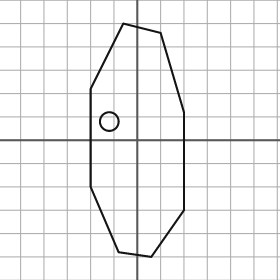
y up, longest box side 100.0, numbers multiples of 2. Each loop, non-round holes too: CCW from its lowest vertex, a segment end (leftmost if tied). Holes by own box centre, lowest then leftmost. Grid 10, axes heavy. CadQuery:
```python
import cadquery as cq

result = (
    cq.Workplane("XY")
    .moveTo(6.0, -50.0)
    .lineTo(20.0, -30.0)
    .lineTo(20.0, 12.0)
    .lineTo(10.0, 46.0)
    .lineTo(-6.0, 50.0)
    .lineTo(-20.0, 22.0)
    .lineTo(-20.0, -20.0)
    .lineTo(-8.0, -48.0)
    .close()
    .moveTo(-12.0, 8.0)
    .circle(4.0)
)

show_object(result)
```